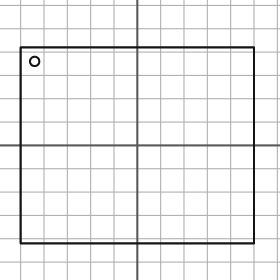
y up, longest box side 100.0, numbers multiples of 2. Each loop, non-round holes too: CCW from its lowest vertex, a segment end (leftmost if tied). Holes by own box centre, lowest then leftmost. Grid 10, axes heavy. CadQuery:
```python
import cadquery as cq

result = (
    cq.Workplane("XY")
    .moveTo(-50.0, -42.0)
    .lineTo(50.0, -42.0)
    .lineTo(50.0, 42.0)
    .lineTo(-50.0, 42.0)
    .close()
    .moveTo(-44.0, 36.0)
    .circle(2.0)
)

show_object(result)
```